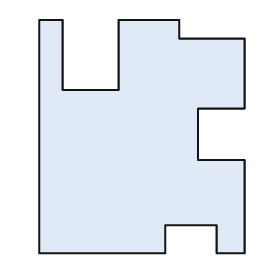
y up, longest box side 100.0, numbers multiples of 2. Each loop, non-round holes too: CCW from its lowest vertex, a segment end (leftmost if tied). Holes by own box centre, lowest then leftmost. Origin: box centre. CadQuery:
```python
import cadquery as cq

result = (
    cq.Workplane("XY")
    .moveTo(-44.0, -50.0)
    .lineTo(10.0, -50.0)
    .lineTo(10.0, -38.0)
    .lineTo(32.0, -38.0)
    .lineTo(32.0, -50.0)
    .lineTo(44.0, -50.0)
    .lineTo(44.0, -10.0)
    .lineTo(24.0, -10.0)
    .lineTo(24.0, 12.0)
    .lineTo(44.0, 12.0)
    .lineTo(44.0, 42.0)
    .lineTo(16.0, 42.0)
    .lineTo(16.0, 50.0)
    .lineTo(-10.0, 50.0)
    .lineTo(-10.0, 20.0)
    .lineTo(-34.0, 20.0)
    .lineTo(-34.0, 50.0)
    .lineTo(-44.0, 50.0)
    .close()
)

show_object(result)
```